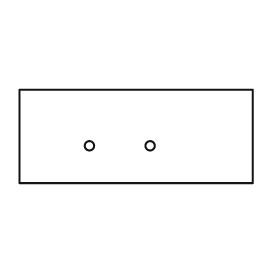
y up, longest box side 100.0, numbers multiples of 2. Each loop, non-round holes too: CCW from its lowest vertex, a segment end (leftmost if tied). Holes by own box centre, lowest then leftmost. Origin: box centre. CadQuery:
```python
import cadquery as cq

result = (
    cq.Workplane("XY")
    .moveTo(-50.0, -20.0)
    .lineTo(50.0, -20.0)
    .lineTo(50.0, 20.0)
    .lineTo(-50.0, 20.0)
    .close()
    .moveTo(-20.0, -4.0)
    .circle(2.0)
    .moveTo(6.0, -4.0)
    .circle(2.0)
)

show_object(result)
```